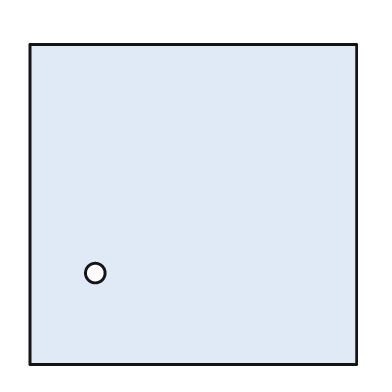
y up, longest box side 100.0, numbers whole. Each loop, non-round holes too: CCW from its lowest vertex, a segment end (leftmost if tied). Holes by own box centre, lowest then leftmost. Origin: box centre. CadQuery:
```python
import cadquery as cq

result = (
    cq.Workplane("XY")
    .moveTo(-50.0, -49.0)
    .lineTo(50.0, -49.0)
    .lineTo(50.0, 49.0)
    .lineTo(-50.0, 49.0)
    .close()
    .moveTo(-30.0, -21.0)
    .circle(3.0)
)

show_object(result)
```